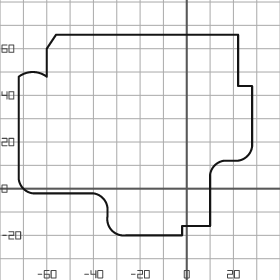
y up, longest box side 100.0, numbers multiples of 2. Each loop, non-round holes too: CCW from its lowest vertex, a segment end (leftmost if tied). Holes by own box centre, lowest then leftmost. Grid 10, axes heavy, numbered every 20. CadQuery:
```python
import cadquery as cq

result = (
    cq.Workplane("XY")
    .moveTo(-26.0, -20.0)
    .lineTo(-2.0, -20.0)
    .lineTo(-2.0, -16.0)
    .lineTo(10.0, -16.0)
    .lineTo(10.0, 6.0)
    .threePointArc((12.0, 10.0), (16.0, 12.0))
    .lineTo(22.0, 12.0)
    .threePointArc((26.0, 14.0), (28.0, 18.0))
    .lineTo(28.0, 44.0)
    .lineTo(22.0, 44.0)
    .lineTo(22.0, 66.0)
    .lineTo(-56.0, 66.0)
    .lineTo(-60.0, 60.0)
    .lineTo(-60.0, 48.0)
    .threePointArc((-66.0, 50.0), (-72.0, 48.0))
    .lineTo(-72.0, 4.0)
    .threePointArc((-70.0, 0.0), (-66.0, -2.0))
    .lineTo(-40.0, -2.0)
    .threePointArc((-36.0, -4.0), (-34.0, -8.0))
    .lineTo(-34.0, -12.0)
    .threePointArc((-32.0, -18.0), (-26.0, -20.0))
    .close()
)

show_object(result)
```